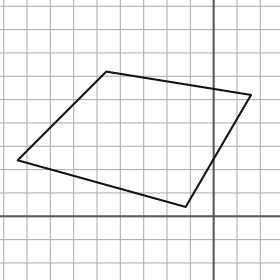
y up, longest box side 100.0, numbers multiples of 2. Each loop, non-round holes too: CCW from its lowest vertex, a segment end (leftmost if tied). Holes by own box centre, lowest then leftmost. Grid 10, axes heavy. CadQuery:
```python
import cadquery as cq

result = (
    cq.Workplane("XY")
    .moveTo(-12.0, 4.0)
    .lineTo(16.0, 52.0)
    .lineTo(-46.0, 62.0)
    .lineTo(-84.0, 24.0)
    .close()
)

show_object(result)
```